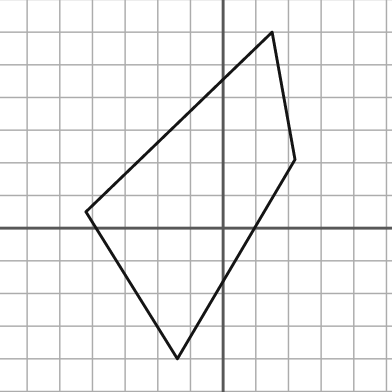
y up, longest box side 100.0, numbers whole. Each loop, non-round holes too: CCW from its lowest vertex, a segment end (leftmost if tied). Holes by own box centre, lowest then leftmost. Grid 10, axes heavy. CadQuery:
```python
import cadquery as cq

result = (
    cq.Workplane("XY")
    .moveTo(-14.0, -40.0)
    .lineTo(22.0, 21.0)
    .lineTo(15.0, 60.0)
    .lineTo(-42.0, 5.0)
    .close()
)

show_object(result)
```